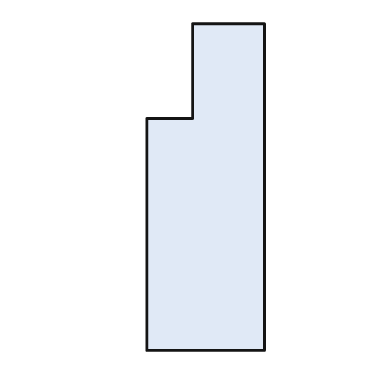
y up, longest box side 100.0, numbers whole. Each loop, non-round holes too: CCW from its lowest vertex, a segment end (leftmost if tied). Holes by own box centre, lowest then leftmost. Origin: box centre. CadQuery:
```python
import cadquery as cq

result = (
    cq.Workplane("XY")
    .moveTo(-18.0, -50.0)
    .lineTo(18.0, -50.0)
    .lineTo(18.0, 50.0)
    .lineTo(-4.0, 50.0)
    .lineTo(-4.0, 21.0)
    .lineTo(-18.0, 21.0)
    .close()
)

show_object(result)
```